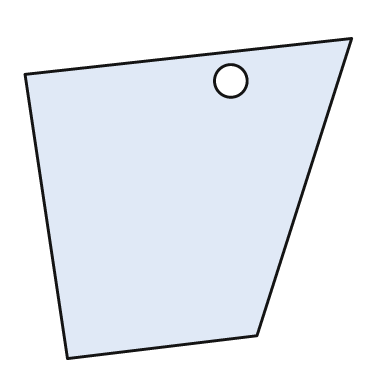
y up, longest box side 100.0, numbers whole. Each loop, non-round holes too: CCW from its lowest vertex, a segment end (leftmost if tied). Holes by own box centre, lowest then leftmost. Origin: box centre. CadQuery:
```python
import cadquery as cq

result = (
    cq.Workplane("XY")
    .moveTo(-37.0, -49.0)
    .lineTo(21.0, -42.0)
    .lineTo(50.0, 49.0)
    .lineTo(-50.0, 38.0)
    .close()
    .moveTo(13.0, 36.0)
    .circle(5.0)
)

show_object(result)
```